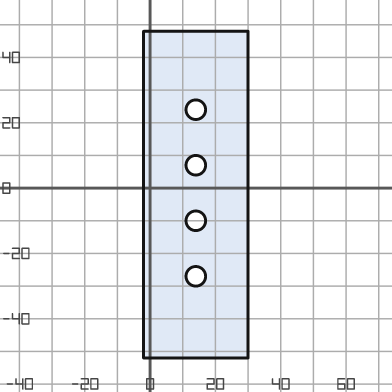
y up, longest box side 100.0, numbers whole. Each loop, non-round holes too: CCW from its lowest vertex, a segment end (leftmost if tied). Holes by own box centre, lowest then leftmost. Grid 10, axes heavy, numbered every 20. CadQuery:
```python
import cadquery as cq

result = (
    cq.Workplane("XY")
    .moveTo(-2.0, -52.0)
    .lineTo(30.0, -52.0)
    .lineTo(30.0, 48.0)
    .lineTo(-2.0, 48.0)
    .close()
    .moveTo(14.0, -27.0)
    .circle(3.0)
    .moveTo(14.0, -10.0)
    .circle(3.0)
    .moveTo(14.0, 7.0)
    .circle(3.0)
    .moveTo(14.0, 24.0)
    .circle(3.0)
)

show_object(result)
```